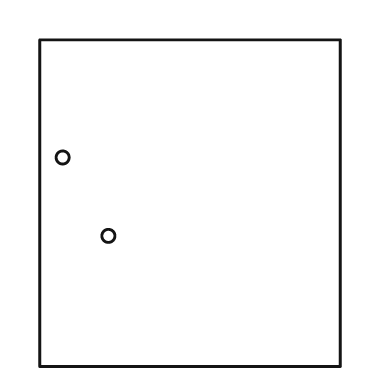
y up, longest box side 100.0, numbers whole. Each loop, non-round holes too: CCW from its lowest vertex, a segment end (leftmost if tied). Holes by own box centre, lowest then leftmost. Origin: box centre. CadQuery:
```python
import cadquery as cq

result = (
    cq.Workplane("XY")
    .moveTo(-46.0, -50.0)
    .lineTo(46.0, -50.0)
    .lineTo(46.0, 50.0)
    .lineTo(-46.0, 50.0)
    .close()
    .moveTo(-25.0, -10.0)
    .circle(2.0)
    .moveTo(-39.0, 14.0)
    .circle(2.0)
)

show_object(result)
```